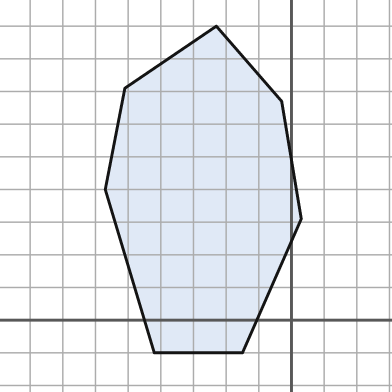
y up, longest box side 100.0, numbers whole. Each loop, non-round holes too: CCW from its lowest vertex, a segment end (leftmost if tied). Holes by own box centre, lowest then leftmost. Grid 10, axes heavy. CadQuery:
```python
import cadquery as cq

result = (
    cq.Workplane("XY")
    .moveTo(-42.0, -10.0)
    .lineTo(-15.0, -10.0)
    .lineTo(3.0, 31.0)
    .lineTo(-3.0, 67.0)
    .lineTo(-23.0, 90.0)
    .lineTo(-51.0, 71.0)
    .lineTo(-57.0, 40.0)
    .close()
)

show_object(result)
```